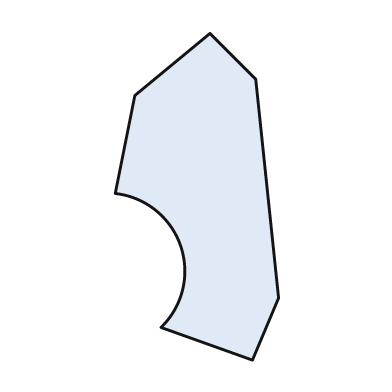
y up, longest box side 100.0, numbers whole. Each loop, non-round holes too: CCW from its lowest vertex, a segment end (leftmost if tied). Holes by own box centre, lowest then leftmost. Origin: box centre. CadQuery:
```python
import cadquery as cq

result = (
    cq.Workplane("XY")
    .moveTo(17.0, -50.0)
    .lineTo(25.0, -31.0)
    .lineTo(18.0, 36.0)
    .lineTo(4.0, 50.0)
    .lineTo(-19.0, 31.0)
    .lineTo(-25.0, 1.0)
    .threePointArc((-5.0, -15.0), (-11.0, -40.0))
    .close()
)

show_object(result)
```